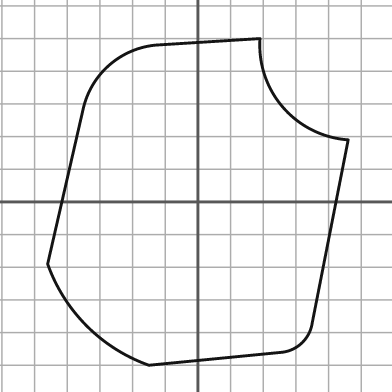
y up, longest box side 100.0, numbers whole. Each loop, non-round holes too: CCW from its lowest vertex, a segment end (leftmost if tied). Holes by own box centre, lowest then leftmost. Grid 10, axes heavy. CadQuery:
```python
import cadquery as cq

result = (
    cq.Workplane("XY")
    .moveTo(-15.0, -50.0)
    .lineTo(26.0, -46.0)
    .threePointArc((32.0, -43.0), (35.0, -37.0))
    .lineTo(46.0, 19.0)
    .threePointArc((26.0, 29.0), (19.0, 50.0))
    .lineTo(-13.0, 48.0)
    .threePointArc((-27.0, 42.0), (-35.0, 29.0))
    .lineTo(-46.0, -19.0)
    .threePointArc((-34.0, -38.0), (-15.0, -50.0))
    .close()
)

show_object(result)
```